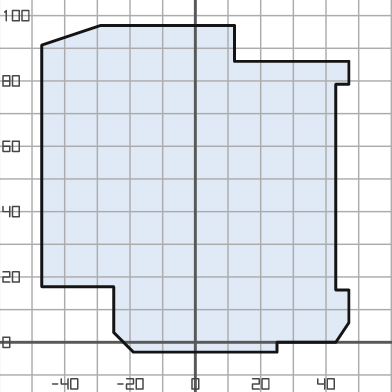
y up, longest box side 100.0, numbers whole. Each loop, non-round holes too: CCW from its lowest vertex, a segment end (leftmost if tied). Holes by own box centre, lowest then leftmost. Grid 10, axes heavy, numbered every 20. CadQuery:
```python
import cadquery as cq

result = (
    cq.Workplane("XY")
    .moveTo(-19.0, -3.0)
    .lineTo(25.0, -3.0)
    .lineTo(25.0, 0.0)
    .lineTo(43.0, 0.0)
    .lineTo(47.0, 6.0)
    .lineTo(47.0, 16.0)
    .lineTo(43.0, 16.0)
    .lineTo(43.0, 79.0)
    .lineTo(47.0, 79.0)
    .lineTo(47.0, 86.0)
    .lineTo(12.0, 86.0)
    .lineTo(12.0, 97.0)
    .lineTo(-29.0, 97.0)
    .lineTo(-47.0, 91.0)
    .lineTo(-47.0, 17.0)
    .lineTo(-25.0, 17.0)
    .lineTo(-25.0, 3.0)
    .close()
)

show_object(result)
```